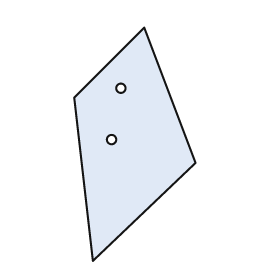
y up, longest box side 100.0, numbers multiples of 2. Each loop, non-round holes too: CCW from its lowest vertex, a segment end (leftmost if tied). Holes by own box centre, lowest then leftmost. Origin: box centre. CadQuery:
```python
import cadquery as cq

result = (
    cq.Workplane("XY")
    .moveTo(-18.0, -50.0)
    .lineTo(26.0, -8.0)
    .lineTo(4.0, 50.0)
    .lineTo(-26.0, 20.0)
    .close()
    .moveTo(-10.0, 2.0)
    .circle(2.0)
    .moveTo(-6.0, 24.0)
    .circle(2.0)
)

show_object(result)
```